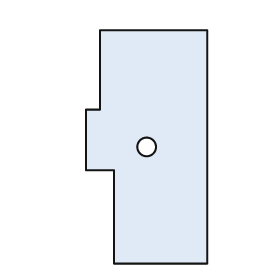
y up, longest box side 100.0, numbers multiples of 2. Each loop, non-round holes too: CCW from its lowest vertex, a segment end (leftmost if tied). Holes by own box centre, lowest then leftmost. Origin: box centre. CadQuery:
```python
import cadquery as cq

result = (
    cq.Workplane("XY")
    .moveTo(-14.0, -50.0)
    .lineTo(26.0, -50.0)
    .lineTo(26.0, 50.0)
    .lineTo(-20.0, 50.0)
    .lineTo(-20.0, 16.0)
    .lineTo(-26.0, 16.0)
    .lineTo(-26.0, -10.0)
    .lineTo(-14.0, -10.0)
    .close()
    .moveTo(0.0, 0.0)
    .circle(4.0)
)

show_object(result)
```